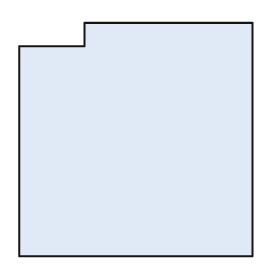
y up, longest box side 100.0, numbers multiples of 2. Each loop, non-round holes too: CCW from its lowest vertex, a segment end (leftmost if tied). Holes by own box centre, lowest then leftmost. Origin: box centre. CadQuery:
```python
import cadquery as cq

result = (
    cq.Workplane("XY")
    .moveTo(-50.0, -50.0)
    .lineTo(50.0, -50.0)
    .lineTo(50.0, 50.0)
    .lineTo(-22.0, 50.0)
    .lineTo(-22.0, 40.0)
    .lineTo(-50.0, 40.0)
    .close()
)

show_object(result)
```